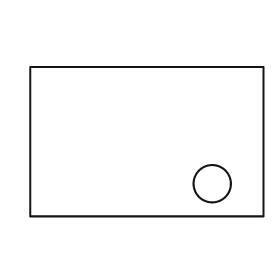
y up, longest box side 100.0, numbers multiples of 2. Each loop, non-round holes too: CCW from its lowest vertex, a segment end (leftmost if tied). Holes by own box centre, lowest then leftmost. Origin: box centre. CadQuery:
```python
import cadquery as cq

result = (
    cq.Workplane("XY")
    .moveTo(-50.0, -32.0)
    .lineTo(50.0, -32.0)
    .lineTo(50.0, 32.0)
    .lineTo(-50.0, 32.0)
    .close()
    .moveTo(28.0, -18.0)
    .circle(8.0)
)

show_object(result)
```